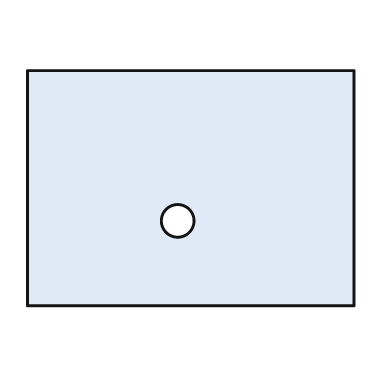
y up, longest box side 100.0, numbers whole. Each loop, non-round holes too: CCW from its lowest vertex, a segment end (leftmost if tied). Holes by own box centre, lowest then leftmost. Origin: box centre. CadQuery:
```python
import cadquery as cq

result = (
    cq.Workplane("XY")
    .moveTo(-50.0, -36.0)
    .lineTo(50.0, -36.0)
    .lineTo(50.0, 36.0)
    .lineTo(-50.0, 36.0)
    .close()
    .moveTo(-4.0, -10.0)
    .circle(5.0)
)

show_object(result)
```